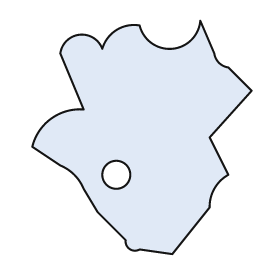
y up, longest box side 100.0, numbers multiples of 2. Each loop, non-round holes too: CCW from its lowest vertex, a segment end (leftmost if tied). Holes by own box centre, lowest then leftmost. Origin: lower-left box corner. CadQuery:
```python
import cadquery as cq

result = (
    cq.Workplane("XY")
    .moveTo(60.0, 0.0)
    .lineTo(76.0, 20.0)
    .threePointArc((78.0, 28.0), (84.0, 34.0))
    .lineTo(76.0, 50.0)
    .lineTo(94.0, 70.0)
    .lineTo(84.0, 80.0)
    .threePointArc((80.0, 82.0), (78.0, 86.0))
    .lineTo(72.0, 100.0)
    .threePointArc((60.0, 88.0), (46.0, 98.0))
    .threePointArc((36.0, 96.0), (30.0, 88.0))
    .threePointArc((20.0, 94.0), (12.0, 86.0))
    .lineTo(22.0, 62.0)
    .threePointArc((8.0, 58.0), (0.0, 46.0))
    .lineTo(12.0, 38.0)
    .threePointArc((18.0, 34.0), (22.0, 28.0))
    .lineTo(28.0, 18.0)
    .lineTo(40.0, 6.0)
    .threePointArc((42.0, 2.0), (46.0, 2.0))
    .close()
    .moveTo(36.0, 34.0)
    .circle(6.0)
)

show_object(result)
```